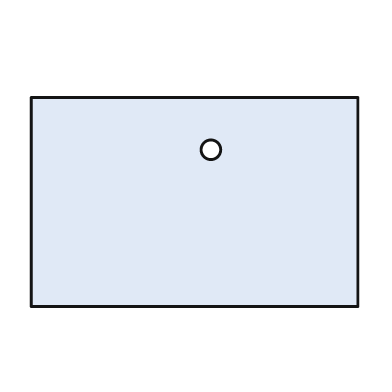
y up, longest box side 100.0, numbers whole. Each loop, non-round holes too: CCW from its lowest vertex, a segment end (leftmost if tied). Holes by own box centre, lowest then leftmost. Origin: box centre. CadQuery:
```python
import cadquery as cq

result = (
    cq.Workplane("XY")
    .moveTo(-50.0, -32.0)
    .lineTo(50.0, -32.0)
    .lineTo(50.0, 32.0)
    .lineTo(-50.0, 32.0)
    .close()
    .moveTo(5.0, 16.0)
    .circle(3.0)
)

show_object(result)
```